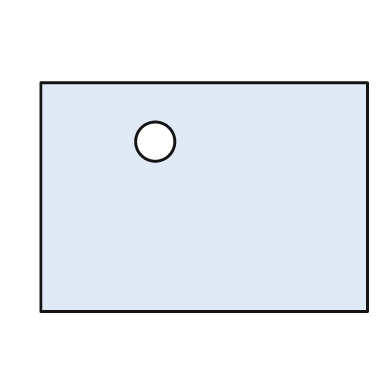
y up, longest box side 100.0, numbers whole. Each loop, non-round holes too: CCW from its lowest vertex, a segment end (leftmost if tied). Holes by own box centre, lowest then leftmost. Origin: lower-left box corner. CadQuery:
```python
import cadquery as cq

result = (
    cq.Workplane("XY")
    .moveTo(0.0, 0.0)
    .lineTo(100.0, 0.0)
    .lineTo(100.0, 70.0)
    .lineTo(0.0, 70.0)
    .close()
    .moveTo(35.0, 52.0)
    .circle(6.0)
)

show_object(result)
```